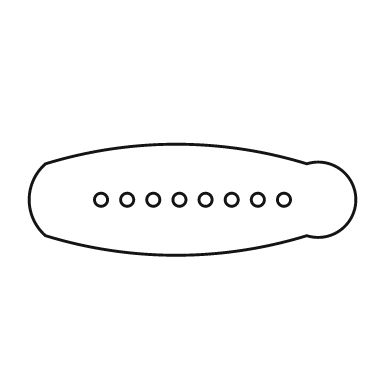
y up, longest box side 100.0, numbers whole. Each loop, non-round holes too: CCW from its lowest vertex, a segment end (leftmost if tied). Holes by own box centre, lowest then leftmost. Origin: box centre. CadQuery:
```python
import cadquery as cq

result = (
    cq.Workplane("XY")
    .moveTo(-45.0, -11.0)
    .threePointArc((-5.0, -17.0), (35.0, -11.0))
    .threePointArc((50.0, 0.0), (35.0, 11.0))
    .threePointArc((-5.0, 17.0), (-45.0, 11.0))
    .threePointArc((-50.0, 0.0), (-45.0, -11.0))
    .close()
    .moveTo(-28.0, 0.0)
    .circle(2.0)
    .moveTo(-20.0, 0.0)
    .circle(2.0)
    .moveTo(-12.0, 0.0)
    .circle(2.0)
    .moveTo(-4.0, 0.0)
    .circle(2.0)
    .moveTo(4.0, 0.0)
    .circle(2.0)
    .moveTo(12.0, 0.0)
    .circle(2.0)
    .moveTo(20.0, 0.0)
    .circle(2.0)
    .moveTo(28.0, 0.0)
    .circle(2.0)
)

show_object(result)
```